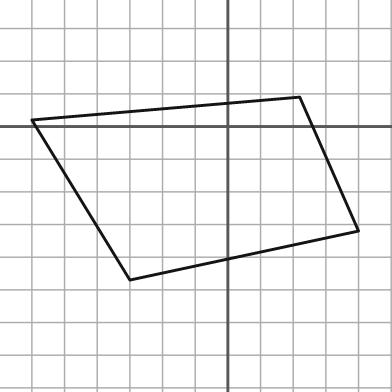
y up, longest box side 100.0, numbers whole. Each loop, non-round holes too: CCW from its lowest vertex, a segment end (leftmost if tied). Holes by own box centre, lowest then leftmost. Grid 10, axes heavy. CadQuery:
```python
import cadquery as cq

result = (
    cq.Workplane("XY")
    .moveTo(-30.0, -47.0)
    .lineTo(40.0, -32.0)
    .lineTo(22.0, 9.0)
    .lineTo(-60.0, 2.0)
    .close()
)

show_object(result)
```